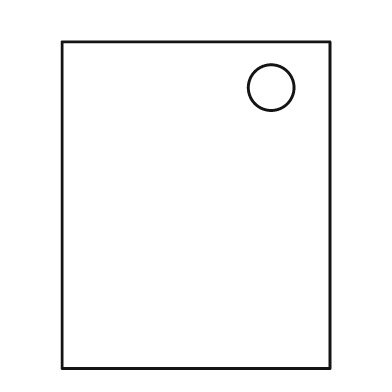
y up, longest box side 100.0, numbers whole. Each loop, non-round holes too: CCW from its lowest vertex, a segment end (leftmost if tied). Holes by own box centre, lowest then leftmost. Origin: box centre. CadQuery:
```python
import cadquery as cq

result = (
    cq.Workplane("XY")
    .moveTo(-41.0, -50.0)
    .lineTo(41.0, -50.0)
    .lineTo(41.0, 50.0)
    .lineTo(-41.0, 50.0)
    .close()
    .moveTo(23.0, 36.0)
    .circle(7.0)
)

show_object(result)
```